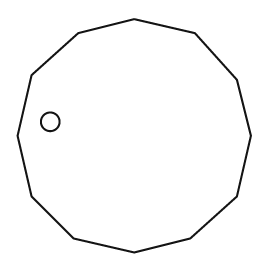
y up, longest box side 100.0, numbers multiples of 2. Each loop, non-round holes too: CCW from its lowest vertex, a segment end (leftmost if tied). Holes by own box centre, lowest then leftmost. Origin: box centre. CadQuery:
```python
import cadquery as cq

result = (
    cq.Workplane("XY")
    .moveTo(0.0, -50.0)
    .lineTo(24.0, -44.0)
    .lineTo(44.0, -26.0)
    .lineTo(50.0, 0.0)
    .lineTo(44.0, 24.0)
    .lineTo(26.0, 44.0)
    .lineTo(0.0, 50.0)
    .lineTo(-24.0, 44.0)
    .lineTo(-44.0, 26.0)
    .lineTo(-50.0, 0.0)
    .lineTo(-44.0, -26.0)
    .lineTo(-26.0, -44.0)
    .close()
    .moveTo(-36.0, 6.0)
    .circle(4.0)
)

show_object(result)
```